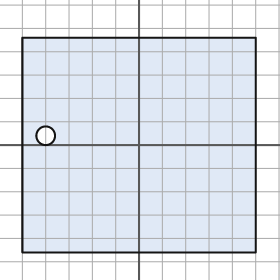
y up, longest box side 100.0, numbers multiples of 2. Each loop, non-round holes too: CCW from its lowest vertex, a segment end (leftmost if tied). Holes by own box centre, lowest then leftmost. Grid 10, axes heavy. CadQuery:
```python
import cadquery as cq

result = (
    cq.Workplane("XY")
    .moveTo(-50.0, -46.0)
    .lineTo(50.0, -46.0)
    .lineTo(50.0, 46.0)
    .lineTo(-50.0, 46.0)
    .close()
    .moveTo(-40.0, 4.0)
    .circle(4.0)
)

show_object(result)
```